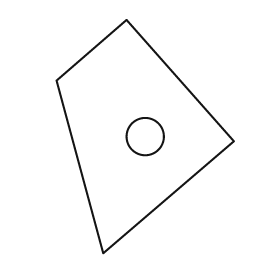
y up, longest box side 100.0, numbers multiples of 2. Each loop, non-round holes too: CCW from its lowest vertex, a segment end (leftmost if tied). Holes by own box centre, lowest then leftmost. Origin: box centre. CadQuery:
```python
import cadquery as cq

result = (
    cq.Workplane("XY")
    .moveTo(-18.0, -50.0)
    .lineTo(38.0, -2.0)
    .lineTo(-8.0, 50.0)
    .lineTo(-38.0, 24.0)
    .close()
    .moveTo(0.0, 0.0)
    .circle(8.0)
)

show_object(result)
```